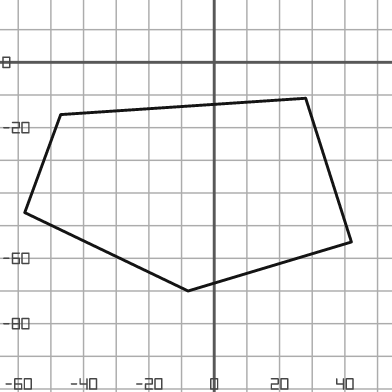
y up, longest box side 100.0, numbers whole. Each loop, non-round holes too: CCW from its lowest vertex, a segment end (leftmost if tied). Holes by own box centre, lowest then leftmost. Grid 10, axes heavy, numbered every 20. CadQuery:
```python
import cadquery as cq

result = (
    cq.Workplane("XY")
    .moveTo(-8.0, -70.0)
    .lineTo(42.0, -55.0)
    .lineTo(28.0, -11.0)
    .lineTo(-47.0, -16.0)
    .lineTo(-58.0, -46.0)
    .close()
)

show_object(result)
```